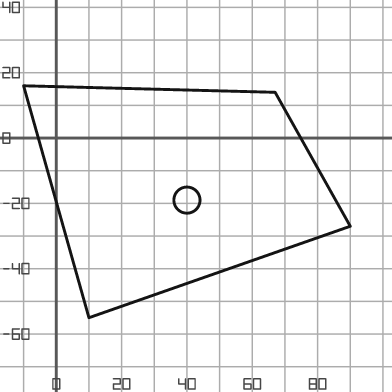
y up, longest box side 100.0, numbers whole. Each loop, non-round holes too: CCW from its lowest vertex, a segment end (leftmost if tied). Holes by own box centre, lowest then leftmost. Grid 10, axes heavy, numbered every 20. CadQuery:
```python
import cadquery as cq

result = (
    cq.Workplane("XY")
    .moveTo(10.0, -55.0)
    .lineTo(90.0, -27.0)
    .lineTo(67.0, 14.0)
    .lineTo(-10.0, 16.0)
    .close()
    .moveTo(40.0, -19.0)
    .circle(4.0)
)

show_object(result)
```